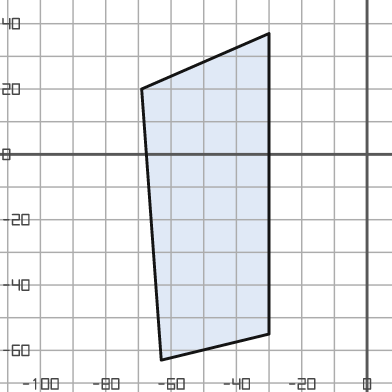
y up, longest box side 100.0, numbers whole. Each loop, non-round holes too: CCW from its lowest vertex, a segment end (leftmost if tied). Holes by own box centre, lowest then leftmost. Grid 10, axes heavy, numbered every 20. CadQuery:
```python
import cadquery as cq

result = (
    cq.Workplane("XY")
    .moveTo(-63.0, -63.0)
    .lineTo(-30.0, -55.0)
    .lineTo(-30.0, 37.0)
    .lineTo(-69.0, 20.0)
    .close()
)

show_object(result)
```